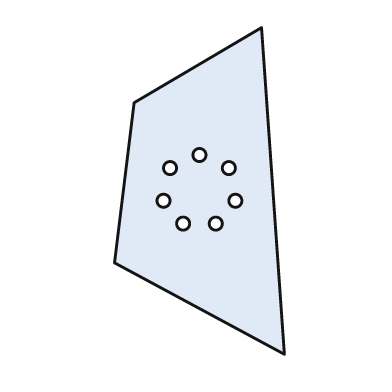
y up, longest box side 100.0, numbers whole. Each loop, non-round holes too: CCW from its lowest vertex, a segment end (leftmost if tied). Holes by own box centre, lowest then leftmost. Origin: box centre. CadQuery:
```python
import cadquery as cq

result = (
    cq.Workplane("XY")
    .moveTo(26.0, -50.0)
    .lineTo(19.0, 50.0)
    .lineTo(-20.0, 27.0)
    .lineTo(-26.0, -22.0)
    .close()
    .moveTo(-5.0, -10.0)
    .circle(2.0)
    .moveTo(5.0, -10.0)
    .circle(2.0)
    .moveTo(-11.0, -3.0)
    .circle(2.0)
    .moveTo(11.0, -3.0)
    .circle(2.0)
    .moveTo(-9.0, 7.0)
    .circle(2.0)
    .moveTo(9.0, 7.0)
    .circle(2.0)
    .moveTo(0.0, 11.0)
    .circle(2.0)
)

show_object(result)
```